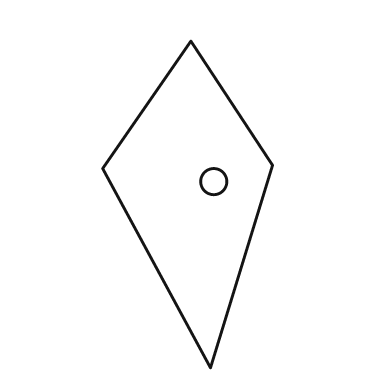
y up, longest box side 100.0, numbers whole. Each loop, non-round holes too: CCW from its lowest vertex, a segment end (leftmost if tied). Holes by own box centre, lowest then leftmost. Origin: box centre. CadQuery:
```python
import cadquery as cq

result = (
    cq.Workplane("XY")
    .moveTo(7.0, -50.0)
    .lineTo(26.0, 12.0)
    .lineTo(1.0, 50.0)
    .lineTo(-26.0, 11.0)
    .close()
    .moveTo(8.0, 7.0)
    .circle(4.0)
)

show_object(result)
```